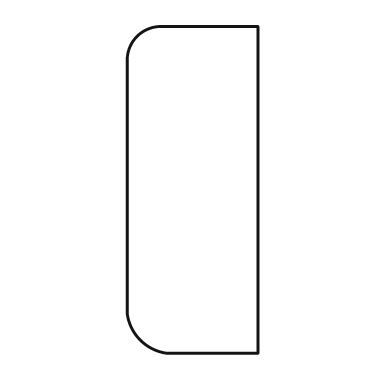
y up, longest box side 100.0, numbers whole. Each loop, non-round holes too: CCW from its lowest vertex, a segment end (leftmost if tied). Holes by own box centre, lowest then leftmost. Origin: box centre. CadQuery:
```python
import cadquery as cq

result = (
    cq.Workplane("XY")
    .moveTo(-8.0, -50.0)
    .lineTo(20.0, -50.0)
    .lineTo(20.0, 50.0)
    .lineTo(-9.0, 50.0)
    .threePointArc((-17.0, 47.0), (-20.0, 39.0))
    .lineTo(-20.0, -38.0)
    .threePointArc((-16.0, -46.0), (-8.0, -50.0))
    .close()
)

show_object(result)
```